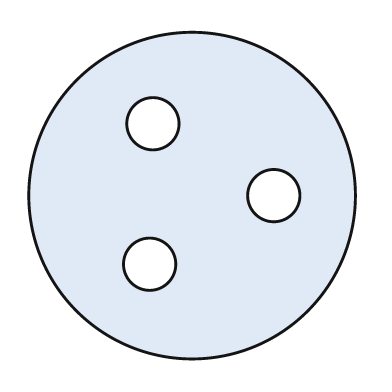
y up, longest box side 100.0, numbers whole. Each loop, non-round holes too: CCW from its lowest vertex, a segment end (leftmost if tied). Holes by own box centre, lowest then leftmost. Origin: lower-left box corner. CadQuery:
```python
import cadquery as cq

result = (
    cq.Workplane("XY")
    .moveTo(50.0, 50.0)
    .circle(50.0)
    .moveTo(37.0, 29.0)
    .circle(8.0)
    .moveTo(75.0, 50.0)
    .circle(8.0)
    .moveTo(38.0, 72.0)
    .circle(8.0)
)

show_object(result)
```